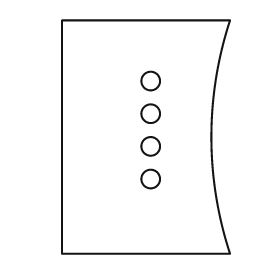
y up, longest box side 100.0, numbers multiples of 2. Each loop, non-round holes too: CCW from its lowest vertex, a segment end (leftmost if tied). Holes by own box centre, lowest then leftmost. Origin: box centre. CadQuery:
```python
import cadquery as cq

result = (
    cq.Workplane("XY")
    .moveTo(-36.0, -50.0)
    .lineTo(36.0, -50.0)
    .threePointArc((28.0, 0.0), (36.0, 50.0))
    .lineTo(-36.0, 50.0)
    .close()
    .moveTo(2.0, -18.0)
    .circle(4.0)
    .moveTo(2.0, -4.0)
    .circle(4.0)
    .moveTo(2.0, 10.0)
    .circle(4.0)
    .moveTo(2.0, 24.0)
    .circle(4.0)
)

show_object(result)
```